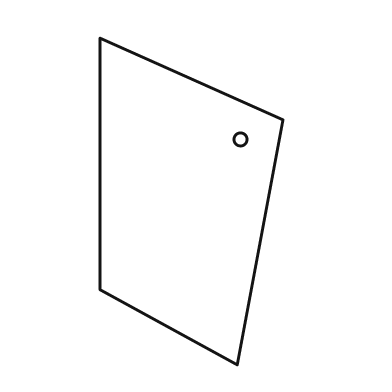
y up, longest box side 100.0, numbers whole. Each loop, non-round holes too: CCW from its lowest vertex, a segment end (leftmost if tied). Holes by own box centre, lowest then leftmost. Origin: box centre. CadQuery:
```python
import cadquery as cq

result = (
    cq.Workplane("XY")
    .moveTo(14.0, -50.0)
    .lineTo(28.0, 25.0)
    .lineTo(-28.0, 50.0)
    .lineTo(-28.0, -27.0)
    .close()
    .moveTo(15.0, 19.0)
    .circle(2.0)
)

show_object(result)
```